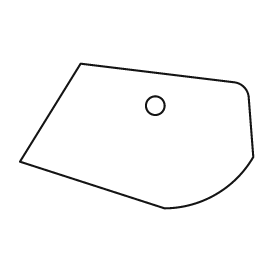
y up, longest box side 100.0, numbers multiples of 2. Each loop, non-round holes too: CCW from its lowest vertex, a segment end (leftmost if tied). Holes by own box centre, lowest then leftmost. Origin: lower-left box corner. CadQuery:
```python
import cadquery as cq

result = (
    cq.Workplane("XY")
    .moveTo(62.0, 0.0)
    .threePointArc((84.0, 6.0), (100.0, 22.0))
    .lineTo(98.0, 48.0)
    .threePointArc((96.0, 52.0), (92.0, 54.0))
    .lineTo(26.0, 62.0)
    .lineTo(0.0, 20.0)
    .close()
    .moveTo(58.0, 44.0)
    .circle(4.0)
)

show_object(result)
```